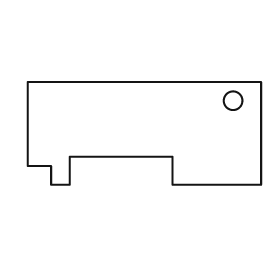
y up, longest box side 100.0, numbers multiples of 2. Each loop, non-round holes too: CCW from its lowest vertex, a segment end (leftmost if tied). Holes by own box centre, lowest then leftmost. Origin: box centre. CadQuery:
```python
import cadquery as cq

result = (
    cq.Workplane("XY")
    .moveTo(-40.0, -22.0)
    .lineTo(-32.0, -22.0)
    .lineTo(-32.0, -10.0)
    .lineTo(12.0, -10.0)
    .lineTo(12.0, -22.0)
    .lineTo(50.0, -22.0)
    .lineTo(50.0, 22.0)
    .lineTo(-50.0, 22.0)
    .lineTo(-50.0, -14.0)
    .lineTo(-40.0, -14.0)
    .close()
    .moveTo(38.0, 14.0)
    .circle(4.0)
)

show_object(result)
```